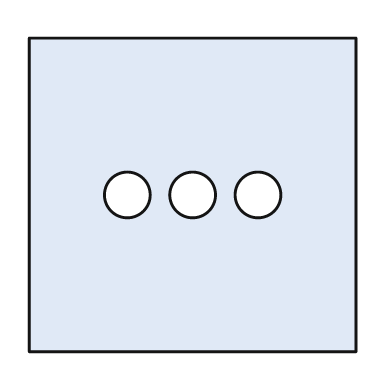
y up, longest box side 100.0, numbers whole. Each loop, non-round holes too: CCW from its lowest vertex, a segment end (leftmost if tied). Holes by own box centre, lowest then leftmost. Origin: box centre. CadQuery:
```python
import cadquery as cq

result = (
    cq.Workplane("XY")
    .moveTo(-50.0, -48.0)
    .lineTo(50.0, -48.0)
    .lineTo(50.0, 48.0)
    .lineTo(-50.0, 48.0)
    .close()
    .moveTo(-20.0, 0.0)
    .circle(7.0)
    .moveTo(0.0, 0.0)
    .circle(7.0)
    .moveTo(20.0, 0.0)
    .circle(7.0)
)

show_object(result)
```